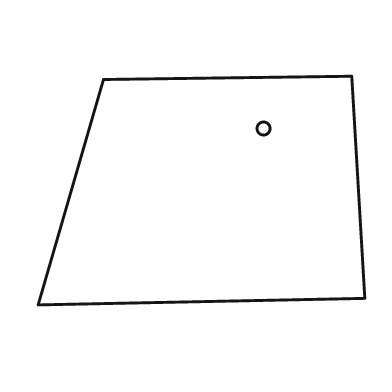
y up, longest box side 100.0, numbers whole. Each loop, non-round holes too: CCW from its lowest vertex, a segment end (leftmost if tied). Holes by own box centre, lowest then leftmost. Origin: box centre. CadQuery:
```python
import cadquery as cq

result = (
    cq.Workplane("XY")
    .moveTo(-50.0, -35.0)
    .lineTo(50.0, -33.0)
    .lineTo(46.0, 35.0)
    .lineTo(-30.0, 34.0)
    .close()
    .moveTo(19.0, 19.0)
    .circle(2.0)
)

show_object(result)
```